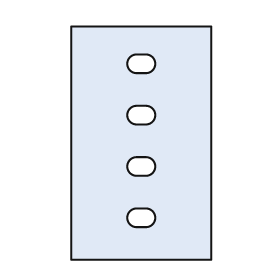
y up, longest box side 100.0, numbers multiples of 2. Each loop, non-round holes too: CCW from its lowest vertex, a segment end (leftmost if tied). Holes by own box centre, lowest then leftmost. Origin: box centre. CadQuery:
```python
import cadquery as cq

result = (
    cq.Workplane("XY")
    .moveTo(-30.0, -50.0)
    .lineTo(30.0, -50.0)
    .lineTo(30.0, 50.0)
    .lineTo(-30.0, 50.0)
    .close()
    .moveTo(-2.0, -36.0)
    .lineTo(2.0, -36.0)
    .threePointArc((6.0, -32.0), (2.0, -28.0))
    .lineTo(-2.0, -28.0)
    .threePointArc((-6.0, -32.0), (-2.0, -36.0))
    .close()
    .moveTo(-2.0, -14.0)
    .lineTo(2.0, -14.0)
    .threePointArc((6.0, -10.0), (2.0, -6.0))
    .lineTo(-2.0, -6.0)
    .threePointArc((-6.0, -10.0), (-2.0, -14.0))
    .close()
    .moveTo(-2.0, 8.0)
    .lineTo(2.0, 8.0)
    .threePointArc((6.0, 12.0), (2.0, 16.0))
    .lineTo(-2.0, 16.0)
    .threePointArc((-6.0, 12.0), (-2.0, 8.0))
    .close()
    .moveTo(-2.0, 30.0)
    .lineTo(2.0, 30.0)
    .threePointArc((6.0, 34.0), (2.0, 38.0))
    .lineTo(-2.0, 38.0)
    .threePointArc((-6.0, 34.0), (-2.0, 30.0))
    .close()
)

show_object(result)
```